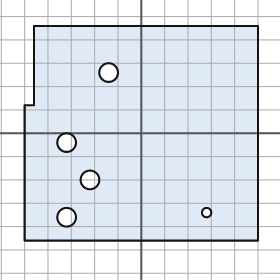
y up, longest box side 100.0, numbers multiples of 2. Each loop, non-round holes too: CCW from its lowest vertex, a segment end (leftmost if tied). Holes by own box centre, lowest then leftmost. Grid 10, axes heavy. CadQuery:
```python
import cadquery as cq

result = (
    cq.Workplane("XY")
    .moveTo(-50.0, -46.0)
    .lineTo(50.0, -46.0)
    .lineTo(50.0, 46.0)
    .lineTo(-46.0, 46.0)
    .lineTo(-46.0, 12.0)
    .lineTo(-50.0, 12.0)
    .close()
    .moveTo(-32.0, -36.0)
    .circle(4.0)
    .moveTo(28.0, -34.0)
    .circle(2.0)
    .moveTo(-22.0, -20.0)
    .circle(4.0)
    .moveTo(-32.0, -4.0)
    .circle(4.0)
    .moveTo(-14.0, 26.0)
    .circle(4.0)
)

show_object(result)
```